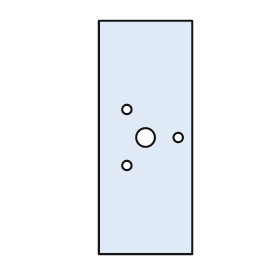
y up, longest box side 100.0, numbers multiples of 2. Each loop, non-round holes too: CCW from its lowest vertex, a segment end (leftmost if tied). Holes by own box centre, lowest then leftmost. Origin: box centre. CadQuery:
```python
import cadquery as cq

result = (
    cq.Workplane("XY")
    .moveTo(-20.0, -50.0)
    .lineTo(20.0, -50.0)
    .lineTo(20.0, 50.0)
    .lineTo(-20.0, 50.0)
    .close()
    .moveTo(-8.0, -12.0)
    .circle(2.0)
    .moveTo(0.0, 0.0)
    .circle(4.0)
    .moveTo(14.0, 0.0)
    .circle(2.0)
    .moveTo(-8.0, 12.0)
    .circle(2.0)
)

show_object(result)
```